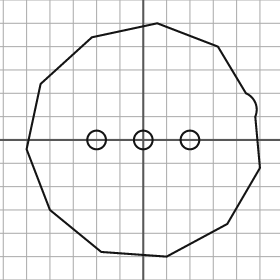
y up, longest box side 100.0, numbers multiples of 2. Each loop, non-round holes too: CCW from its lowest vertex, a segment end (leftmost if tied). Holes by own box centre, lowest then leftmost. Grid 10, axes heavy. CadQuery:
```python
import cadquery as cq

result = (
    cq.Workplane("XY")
    .moveTo(10.0, -50.0)
    .lineTo(36.0, -36.0)
    .lineTo(50.0, -12.0)
    .lineTo(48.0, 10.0)
    .threePointArc((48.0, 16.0), (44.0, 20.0))
    .lineTo(32.0, 40.0)
    .lineTo(6.0, 50.0)
    .lineTo(-22.0, 44.0)
    .lineTo(-44.0, 24.0)
    .lineTo(-50.0, -4.0)
    .lineTo(-40.0, -30.0)
    .lineTo(-18.0, -48.0)
    .close()
    .moveTo(-20.0, 0.0)
    .circle(4.0)
    .moveTo(0.0, 0.0)
    .circle(4.0)
    .moveTo(20.0, 0.0)
    .circle(4.0)
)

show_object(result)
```